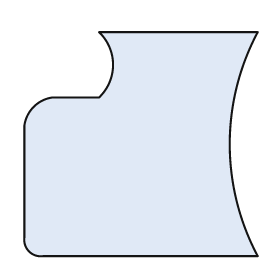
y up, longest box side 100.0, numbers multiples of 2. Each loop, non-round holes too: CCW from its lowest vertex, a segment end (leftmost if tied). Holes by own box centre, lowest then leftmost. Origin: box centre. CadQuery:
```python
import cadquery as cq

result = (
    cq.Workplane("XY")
    .moveTo(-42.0, -48.0)
    .lineTo(50.0, -48.0)
    .threePointArc((38.0, 0.0), (50.0, 48.0))
    .lineTo(-18.0, 48.0)
    .threePointArc((-12.0, 34.0), (-18.0, 20.0))
    .lineTo(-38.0, 20.0)
    .threePointArc((-46.0, 16.0), (-50.0, 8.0))
    .lineTo(-50.0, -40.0)
    .threePointArc((-48.0, -46.0), (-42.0, -48.0))
    .close()
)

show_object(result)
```